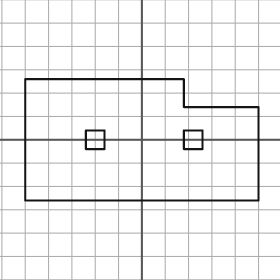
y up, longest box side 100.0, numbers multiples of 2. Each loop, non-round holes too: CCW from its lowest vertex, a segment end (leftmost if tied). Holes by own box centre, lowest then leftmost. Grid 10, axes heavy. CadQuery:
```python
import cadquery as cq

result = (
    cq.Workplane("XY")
    .moveTo(-50.0, -26.0)
    .lineTo(50.0, -26.0)
    .lineTo(50.0, 14.0)
    .lineTo(18.0, 14.0)
    .lineTo(18.0, 26.0)
    .lineTo(-50.0, 26.0)
    .close()
    .moveTo(-24.0, -4.0)
    .lineTo(-16.0, -4.0)
    .lineTo(-16.0, 4.0)
    .lineTo(-24.0, 4.0)
    .close()
    .moveTo(18.0, -4.0)
    .lineTo(26.0, -4.0)
    .lineTo(26.0, 4.0)
    .lineTo(18.0, 4.0)
    .close()
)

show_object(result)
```